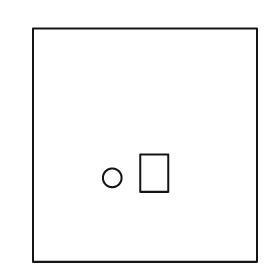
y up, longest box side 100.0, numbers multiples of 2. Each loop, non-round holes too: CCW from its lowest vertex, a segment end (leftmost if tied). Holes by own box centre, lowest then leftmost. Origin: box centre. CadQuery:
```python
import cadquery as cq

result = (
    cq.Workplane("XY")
    .moveTo(-48.0, -50.0)
    .lineTo(48.0, -50.0)
    .lineTo(48.0, 50.0)
    .lineTo(-48.0, 50.0)
    .close()
    .moveTo(-14.0, -14.0)
    .circle(4.0)
    .moveTo(-2.0, -20.0)
    .lineTo(10.0, -20.0)
    .lineTo(10.0, -4.0)
    .lineTo(-2.0, -4.0)
    .close()
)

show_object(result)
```